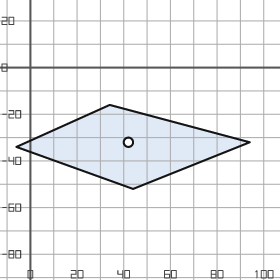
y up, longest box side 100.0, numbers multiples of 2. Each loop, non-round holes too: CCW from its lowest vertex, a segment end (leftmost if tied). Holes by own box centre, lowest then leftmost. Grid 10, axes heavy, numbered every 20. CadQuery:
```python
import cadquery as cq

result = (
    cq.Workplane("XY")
    .moveTo(44.0, -52.0)
    .lineTo(94.0, -32.0)
    .lineTo(34.0, -16.0)
    .lineTo(-6.0, -34.0)
    .close()
    .moveTo(42.0, -32.0)
    .circle(2.0)
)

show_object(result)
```